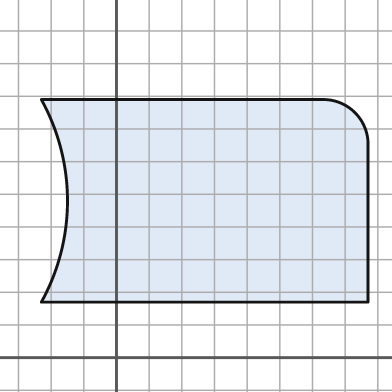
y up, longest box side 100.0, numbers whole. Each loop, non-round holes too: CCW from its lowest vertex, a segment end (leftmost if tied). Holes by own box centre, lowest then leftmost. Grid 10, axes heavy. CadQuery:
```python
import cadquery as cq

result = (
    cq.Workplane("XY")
    .moveTo(-23.0, 17.0)
    .lineTo(77.0, 17.0)
    .lineTo(77.0, 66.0)
    .threePointArc((73.0, 75.0), (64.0, 79.0))
    .lineTo(-23.0, 79.0)
    .threePointArc((-15.0, 48.0), (-23.0, 17.0))
    .close()
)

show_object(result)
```